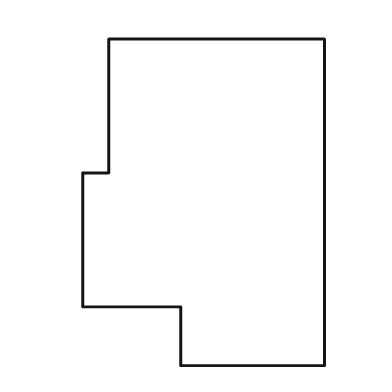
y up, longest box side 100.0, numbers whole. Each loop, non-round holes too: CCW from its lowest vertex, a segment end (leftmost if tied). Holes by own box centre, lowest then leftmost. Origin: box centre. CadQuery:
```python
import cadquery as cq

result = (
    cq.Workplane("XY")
    .moveTo(-7.0, -50.0)
    .lineTo(37.0, -50.0)
    .lineTo(37.0, 50.0)
    .lineTo(-29.0, 50.0)
    .lineTo(-29.0, 9.0)
    .lineTo(-37.0, 9.0)
    .lineTo(-37.0, -32.0)
    .lineTo(-7.0, -32.0)
    .close()
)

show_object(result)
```